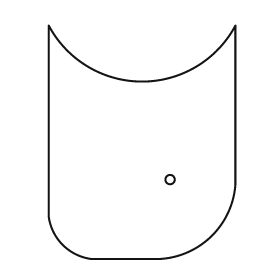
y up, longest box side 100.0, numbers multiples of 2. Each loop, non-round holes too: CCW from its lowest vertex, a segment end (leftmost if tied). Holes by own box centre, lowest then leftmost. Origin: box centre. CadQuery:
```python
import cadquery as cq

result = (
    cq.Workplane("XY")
    .moveTo(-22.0, -50.0)
    .lineTo(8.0, -50.0)
    .threePointArc((30.0, -40.0), (40.0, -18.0))
    .lineTo(40.0, 50.0)
    .threePointArc((0.0, 26.0), (-40.0, 50.0))
    .lineTo(-40.0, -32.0)
    .threePointArc((-34.0, -44.0), (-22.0, -50.0))
    .close()
    .moveTo(12.0, -16.0)
    .circle(2.0)
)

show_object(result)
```